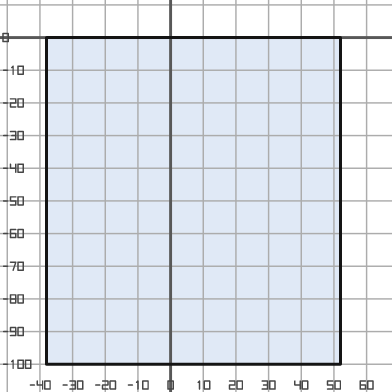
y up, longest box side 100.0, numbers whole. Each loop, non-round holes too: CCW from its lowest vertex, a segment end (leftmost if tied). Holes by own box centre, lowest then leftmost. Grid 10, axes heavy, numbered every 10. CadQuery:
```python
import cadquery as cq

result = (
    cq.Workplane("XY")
    .moveTo(-38.0, -100.0)
    .lineTo(52.0, -100.0)
    .lineTo(52.0, 0.0)
    .lineTo(-38.0, 0.0)
    .close()
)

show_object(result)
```